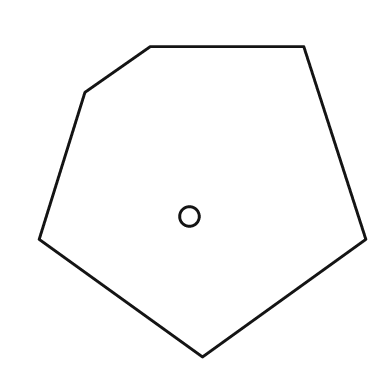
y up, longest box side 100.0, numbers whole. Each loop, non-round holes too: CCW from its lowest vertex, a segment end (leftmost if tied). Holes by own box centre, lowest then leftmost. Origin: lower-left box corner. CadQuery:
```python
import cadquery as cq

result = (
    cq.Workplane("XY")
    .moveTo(50.0, 0.0)
    .lineTo(100.0, 36.0)
    .lineTo(81.0, 95.0)
    .lineTo(34.0, 95.0)
    .lineTo(14.0, 81.0)
    .lineTo(0.0, 36.0)
    .close()
    .moveTo(46.0, 43.0)
    .circle(3.0)
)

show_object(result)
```